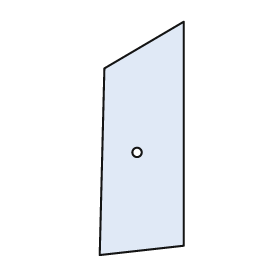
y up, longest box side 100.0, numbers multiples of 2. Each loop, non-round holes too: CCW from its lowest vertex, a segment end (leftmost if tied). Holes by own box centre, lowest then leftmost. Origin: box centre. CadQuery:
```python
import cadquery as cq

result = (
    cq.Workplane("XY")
    .moveTo(-18.0, -50.0)
    .lineTo(18.0, -46.0)
    .lineTo(18.0, 50.0)
    .lineTo(-16.0, 30.0)
    .close()
    .moveTo(-2.0, -6.0)
    .circle(2.0)
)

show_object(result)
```